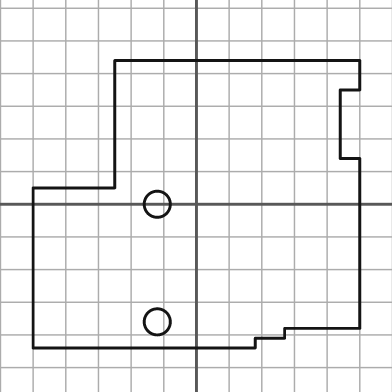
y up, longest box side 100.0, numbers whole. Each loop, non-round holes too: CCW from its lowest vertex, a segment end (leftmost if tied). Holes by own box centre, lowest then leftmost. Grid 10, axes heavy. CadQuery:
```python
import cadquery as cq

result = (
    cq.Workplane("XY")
    .moveTo(-50.0, -44.0)
    .lineTo(18.0, -44.0)
    .lineTo(18.0, -41.0)
    .lineTo(27.0, -41.0)
    .lineTo(27.0, -38.0)
    .lineTo(50.0, -38.0)
    .lineTo(50.0, 14.0)
    .lineTo(44.0, 14.0)
    .lineTo(44.0, 35.0)
    .lineTo(50.0, 35.0)
    .lineTo(50.0, 44.0)
    .lineTo(-25.0, 44.0)
    .lineTo(-25.0, 5.0)
    .lineTo(-50.0, 5.0)
    .close()
    .moveTo(-12.0, -36.0)
    .circle(4.0)
    .moveTo(-12.0, 0.0)
    .circle(4.0)
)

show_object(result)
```